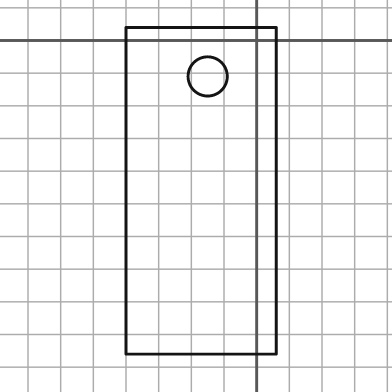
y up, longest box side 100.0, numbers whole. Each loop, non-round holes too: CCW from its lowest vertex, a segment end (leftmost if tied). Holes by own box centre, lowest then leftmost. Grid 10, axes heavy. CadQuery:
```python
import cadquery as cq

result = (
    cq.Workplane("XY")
    .moveTo(-40.0, -96.0)
    .lineTo(6.0, -96.0)
    .lineTo(6.0, 4.0)
    .lineTo(-40.0, 4.0)
    .close()
    .moveTo(-15.0, -11.0)
    .circle(6.0)
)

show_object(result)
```